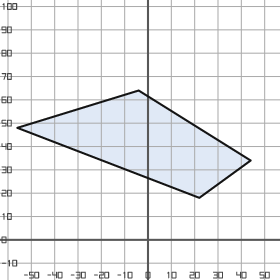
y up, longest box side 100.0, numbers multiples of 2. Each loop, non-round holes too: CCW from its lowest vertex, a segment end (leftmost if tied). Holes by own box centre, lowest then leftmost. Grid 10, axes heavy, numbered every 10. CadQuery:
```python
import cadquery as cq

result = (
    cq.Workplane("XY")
    .moveTo(22.0, 18.0)
    .lineTo(44.0, 34.0)
    .lineTo(-4.0, 64.0)
    .lineTo(-56.0, 48.0)
    .close()
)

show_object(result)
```